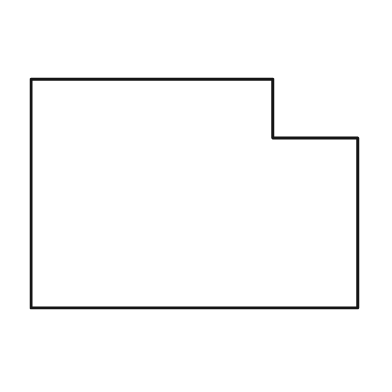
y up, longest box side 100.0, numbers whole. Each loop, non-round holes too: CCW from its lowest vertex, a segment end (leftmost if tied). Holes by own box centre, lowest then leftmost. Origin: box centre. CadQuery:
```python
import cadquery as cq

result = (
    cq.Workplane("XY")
    .moveTo(-50.0, -35.0)
    .lineTo(50.0, -35.0)
    .lineTo(50.0, 17.0)
    .lineTo(24.0, 17.0)
    .lineTo(24.0, 35.0)
    .lineTo(-50.0, 35.0)
    .close()
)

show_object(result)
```